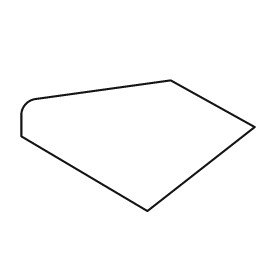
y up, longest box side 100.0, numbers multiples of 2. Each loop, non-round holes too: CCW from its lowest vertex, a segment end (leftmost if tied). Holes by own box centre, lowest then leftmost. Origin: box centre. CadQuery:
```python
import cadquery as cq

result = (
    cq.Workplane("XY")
    .moveTo(4.0, -28.0)
    .lineTo(50.0, 8.0)
    .lineTo(14.0, 28.0)
    .lineTo(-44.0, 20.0)
    .threePointArc((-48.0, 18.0), (-50.0, 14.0))
    .lineTo(-50.0, 4.0)
    .close()
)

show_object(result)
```